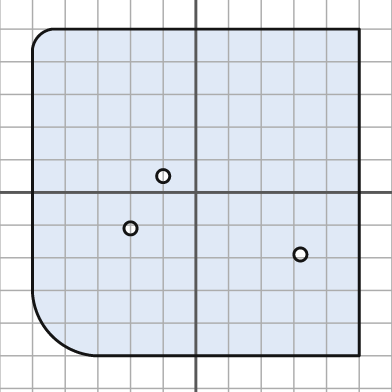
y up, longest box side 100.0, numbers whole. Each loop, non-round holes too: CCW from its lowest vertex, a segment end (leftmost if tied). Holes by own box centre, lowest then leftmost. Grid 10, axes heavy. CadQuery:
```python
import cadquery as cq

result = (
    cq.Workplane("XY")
    .moveTo(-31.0, -50.0)
    .lineTo(50.0, -50.0)
    .lineTo(50.0, 50.0)
    .lineTo(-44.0, 50.0)
    .threePointArc((-48.0, 48.0), (-50.0, 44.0))
    .lineTo(-50.0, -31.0)
    .threePointArc((-44.0, -44.0), (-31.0, -50.0))
    .close()
    .moveTo(32.0, -19.0)
    .circle(2.0)
    .moveTo(-20.0, -11.0)
    .circle(2.0)
    .moveTo(-10.0, 5.0)
    .circle(2.0)
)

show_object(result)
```